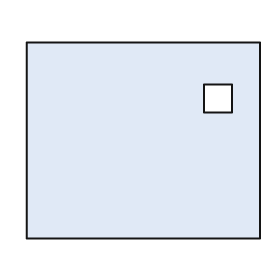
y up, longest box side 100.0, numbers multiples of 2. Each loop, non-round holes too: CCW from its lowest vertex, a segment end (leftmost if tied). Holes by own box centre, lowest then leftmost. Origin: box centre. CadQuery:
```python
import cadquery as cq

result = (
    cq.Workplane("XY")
    .moveTo(-50.0, -42.0)
    .lineTo(50.0, -42.0)
    .lineTo(50.0, 42.0)
    .lineTo(-50.0, 42.0)
    .close()
    .moveTo(26.0, 12.0)
    .lineTo(38.0, 12.0)
    .lineTo(38.0, 24.0)
    .lineTo(26.0, 24.0)
    .close()
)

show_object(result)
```